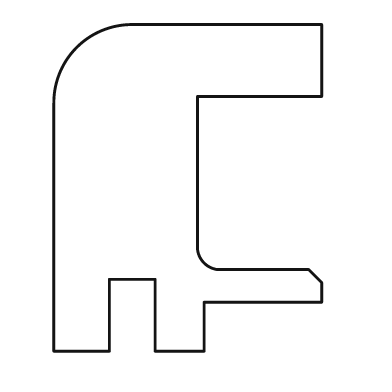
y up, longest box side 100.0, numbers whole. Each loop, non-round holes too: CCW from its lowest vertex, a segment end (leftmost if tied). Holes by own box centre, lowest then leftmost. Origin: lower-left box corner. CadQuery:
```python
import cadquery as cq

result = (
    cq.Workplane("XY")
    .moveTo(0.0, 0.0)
    .lineTo(17.0, 0.0)
    .lineTo(17.0, 22.0)
    .lineTo(31.0, 22.0)
    .lineTo(31.0, 0.0)
    .lineTo(46.0, 0.0)
    .lineTo(46.0, 15.0)
    .lineTo(82.0, 15.0)
    .lineTo(82.0, 21.0)
    .lineTo(78.0, 25.0)
    .lineTo(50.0, 25.0)
    .threePointArc((46.0, 27.0), (44.0, 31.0))
    .lineTo(44.0, 78.0)
    .lineTo(82.0, 78.0)
    .lineTo(82.0, 100.0)
    .lineTo(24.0, 100.0)
    .threePointArc((7.0, 93.0), (0.0, 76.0))
    .close()
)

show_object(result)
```